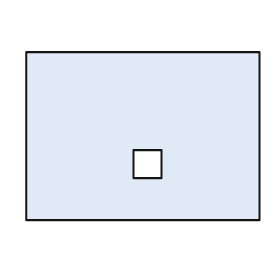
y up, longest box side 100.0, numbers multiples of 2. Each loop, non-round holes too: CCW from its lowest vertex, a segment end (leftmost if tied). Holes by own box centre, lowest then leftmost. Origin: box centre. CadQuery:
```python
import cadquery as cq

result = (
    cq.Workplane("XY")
    .moveTo(-50.0, -36.0)
    .lineTo(50.0, -36.0)
    .lineTo(50.0, 36.0)
    .lineTo(-50.0, 36.0)
    .close()
    .moveTo(-4.0, -18.0)
    .lineTo(8.0, -18.0)
    .lineTo(8.0, -6.0)
    .lineTo(-4.0, -6.0)
    .close()
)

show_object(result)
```